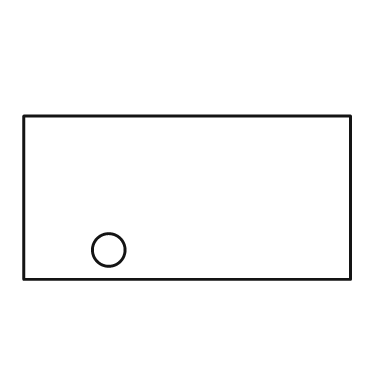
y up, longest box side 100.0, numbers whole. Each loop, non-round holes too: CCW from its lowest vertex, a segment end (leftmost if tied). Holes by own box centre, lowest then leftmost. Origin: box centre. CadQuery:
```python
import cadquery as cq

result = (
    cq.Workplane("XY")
    .moveTo(-50.0, -25.0)
    .lineTo(50.0, -25.0)
    .lineTo(50.0, 25.0)
    .lineTo(-50.0, 25.0)
    .close()
    .moveTo(-24.0, -16.0)
    .circle(5.0)
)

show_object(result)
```